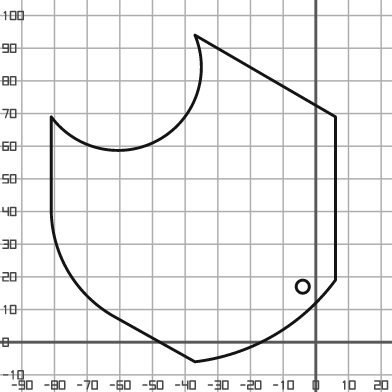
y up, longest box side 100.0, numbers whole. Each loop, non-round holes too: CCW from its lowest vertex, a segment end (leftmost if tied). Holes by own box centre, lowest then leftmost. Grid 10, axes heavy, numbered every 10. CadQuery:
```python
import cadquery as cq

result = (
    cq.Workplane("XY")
    .moveTo(-37.0, -6.0)
    .threePointArc((-13.0, 2.0), (6.0, 19.0))
    .lineTo(6.0, 69.0)
    .lineTo(-37.0, 94.0)
    .threePointArc((-48.0, 62.0), (-81.0, 69.0))
    .lineTo(-81.0, 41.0)
    .threePointArc((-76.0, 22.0), (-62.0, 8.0))
    .close()
    .moveTo(-4.0, 17.0)
    .circle(2.0)
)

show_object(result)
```